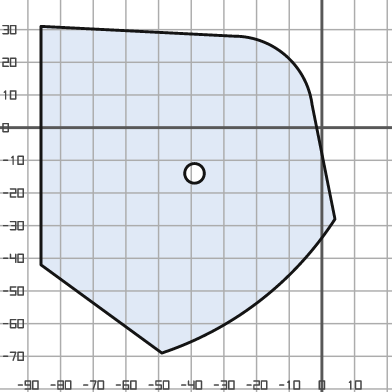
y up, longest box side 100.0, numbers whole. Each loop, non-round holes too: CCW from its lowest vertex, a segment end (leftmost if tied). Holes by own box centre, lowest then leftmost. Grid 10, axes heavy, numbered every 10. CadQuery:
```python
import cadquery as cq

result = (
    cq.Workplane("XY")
    .moveTo(-49.0, -69.0)
    .threePointArc((-19.0, -53.0), (4.0, -28.0))
    .lineTo(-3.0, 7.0)
    .threePointArc((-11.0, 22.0), (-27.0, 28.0))
    .lineTo(-86.0, 31.0)
    .lineTo(-86.0, -42.0)
    .close()
    .moveTo(-39.0, -14.0)
    .circle(3.0)
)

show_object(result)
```